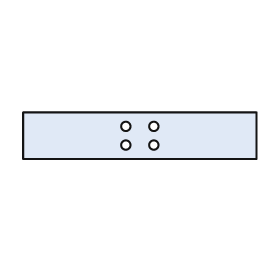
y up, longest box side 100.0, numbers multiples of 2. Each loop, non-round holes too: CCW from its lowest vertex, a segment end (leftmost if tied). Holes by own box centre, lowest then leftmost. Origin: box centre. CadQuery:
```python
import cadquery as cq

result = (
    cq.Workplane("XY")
    .moveTo(-50.0, -10.0)
    .lineTo(50.0, -10.0)
    .lineTo(50.0, 10.0)
    .lineTo(-50.0, 10.0)
    .close()
    .moveTo(-6.0, -4.0)
    .circle(2.0)
    .moveTo(6.0, -4.0)
    .circle(2.0)
    .moveTo(-6.0, 4.0)
    .circle(2.0)
    .moveTo(6.0, 4.0)
    .circle(2.0)
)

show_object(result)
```